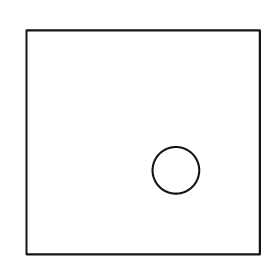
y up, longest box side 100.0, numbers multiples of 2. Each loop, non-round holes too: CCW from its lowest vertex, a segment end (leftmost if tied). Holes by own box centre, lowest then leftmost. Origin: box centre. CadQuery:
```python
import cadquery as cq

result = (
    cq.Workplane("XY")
    .moveTo(-50.0, -48.0)
    .lineTo(50.0, -48.0)
    .lineTo(50.0, 48.0)
    .lineTo(-50.0, 48.0)
    .close()
    .moveTo(14.0, -12.0)
    .circle(10.0)
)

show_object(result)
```